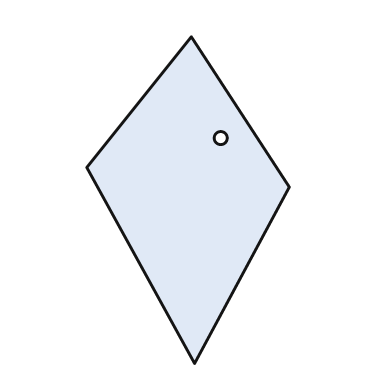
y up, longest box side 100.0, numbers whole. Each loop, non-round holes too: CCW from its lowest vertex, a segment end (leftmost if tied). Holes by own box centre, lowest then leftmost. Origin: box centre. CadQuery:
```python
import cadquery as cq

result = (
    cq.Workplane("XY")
    .moveTo(2.0, -50.0)
    .lineTo(31.0, 4.0)
    .lineTo(1.0, 50.0)
    .lineTo(-31.0, 10.0)
    .close()
    .moveTo(10.0, 19.0)
    .circle(2.0)
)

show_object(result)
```